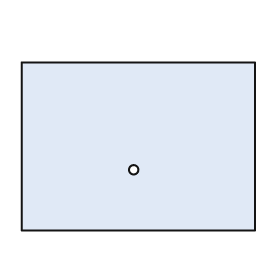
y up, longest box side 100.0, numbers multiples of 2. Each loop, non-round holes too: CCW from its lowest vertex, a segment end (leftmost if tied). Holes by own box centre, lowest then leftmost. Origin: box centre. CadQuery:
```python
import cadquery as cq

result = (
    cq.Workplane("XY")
    .moveTo(-50.0, -36.0)
    .lineTo(50.0, -36.0)
    .lineTo(50.0, 36.0)
    .lineTo(-50.0, 36.0)
    .close()
    .moveTo(-2.0, -10.0)
    .circle(2.0)
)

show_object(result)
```